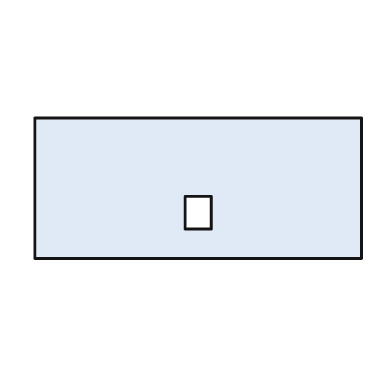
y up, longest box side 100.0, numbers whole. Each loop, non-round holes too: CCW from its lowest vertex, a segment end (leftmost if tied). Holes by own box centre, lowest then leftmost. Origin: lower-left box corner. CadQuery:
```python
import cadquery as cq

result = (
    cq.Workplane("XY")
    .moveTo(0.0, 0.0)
    .lineTo(100.0, 0.0)
    .lineTo(100.0, 43.0)
    .lineTo(0.0, 43.0)
    .close()
    .moveTo(46.0, 9.0)
    .lineTo(54.0, 9.0)
    .lineTo(54.0, 19.0)
    .lineTo(46.0, 19.0)
    .close()
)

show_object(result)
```